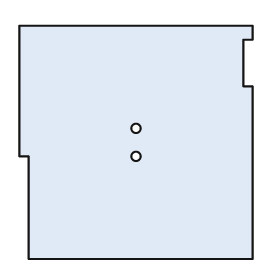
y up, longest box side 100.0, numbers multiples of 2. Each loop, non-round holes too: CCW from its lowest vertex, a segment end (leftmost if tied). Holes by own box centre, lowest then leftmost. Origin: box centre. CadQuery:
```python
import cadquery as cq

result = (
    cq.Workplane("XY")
    .moveTo(-46.0, -50.0)
    .lineTo(50.0, -50.0)
    .lineTo(50.0, 24.0)
    .lineTo(46.0, 24.0)
    .lineTo(46.0, 44.0)
    .lineTo(50.0, 44.0)
    .lineTo(50.0, 50.0)
    .lineTo(-50.0, 50.0)
    .lineTo(-50.0, -6.0)
    .lineTo(-46.0, -6.0)
    .close()
    .moveTo(0.0, -6.0)
    .circle(2.0)
    .moveTo(0.0, 6.0)
    .circle(2.0)
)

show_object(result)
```